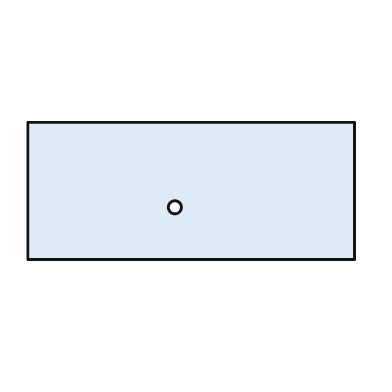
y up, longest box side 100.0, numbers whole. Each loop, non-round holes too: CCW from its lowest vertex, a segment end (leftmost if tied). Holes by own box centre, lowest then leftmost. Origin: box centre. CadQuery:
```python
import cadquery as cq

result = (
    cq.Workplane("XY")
    .moveTo(-50.0, -21.0)
    .lineTo(50.0, -21.0)
    .lineTo(50.0, 21.0)
    .lineTo(-50.0, 21.0)
    .close()
    .moveTo(-5.0, -5.0)
    .circle(2.0)
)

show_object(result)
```